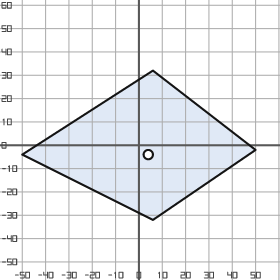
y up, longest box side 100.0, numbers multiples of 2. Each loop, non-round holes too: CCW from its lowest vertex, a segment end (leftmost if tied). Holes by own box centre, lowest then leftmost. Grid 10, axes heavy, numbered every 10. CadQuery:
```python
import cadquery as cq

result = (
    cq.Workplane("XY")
    .moveTo(6.0, -32.0)
    .lineTo(50.0, -2.0)
    .lineTo(6.0, 32.0)
    .lineTo(-50.0, -4.0)
    .close()
    .moveTo(4.0, -4.0)
    .circle(2.0)
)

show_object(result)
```